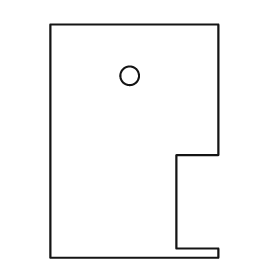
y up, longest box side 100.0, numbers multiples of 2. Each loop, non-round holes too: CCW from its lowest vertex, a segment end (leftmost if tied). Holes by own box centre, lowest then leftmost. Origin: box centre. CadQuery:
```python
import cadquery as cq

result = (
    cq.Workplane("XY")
    .moveTo(-36.0, -50.0)
    .lineTo(36.0, -50.0)
    .lineTo(36.0, -46.0)
    .lineTo(18.0, -46.0)
    .lineTo(18.0, -6.0)
    .lineTo(36.0, -6.0)
    .lineTo(36.0, 50.0)
    .lineTo(-36.0, 50.0)
    .close()
    .moveTo(-2.0, 28.0)
    .circle(4.0)
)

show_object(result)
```